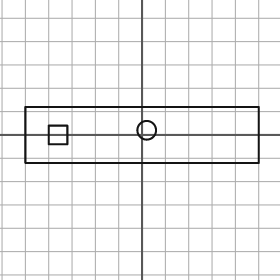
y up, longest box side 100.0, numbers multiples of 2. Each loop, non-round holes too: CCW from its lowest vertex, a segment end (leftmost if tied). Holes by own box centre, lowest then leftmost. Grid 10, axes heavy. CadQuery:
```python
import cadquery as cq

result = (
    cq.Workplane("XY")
    .moveTo(-50.0, -12.0)
    .lineTo(50.0, -12.0)
    .lineTo(50.0, 12.0)
    .lineTo(-50.0, 12.0)
    .close()
    .moveTo(-40.0, -4.0)
    .lineTo(-32.0, -4.0)
    .lineTo(-32.0, 4.0)
    .lineTo(-40.0, 4.0)
    .close()
    .moveTo(2.0, 2.0)
    .circle(4.0)
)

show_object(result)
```